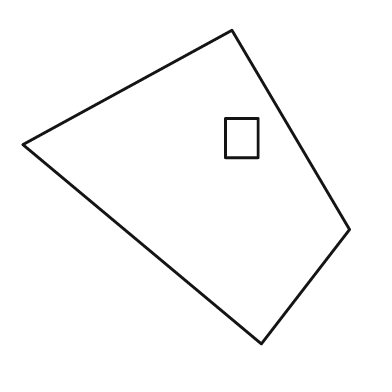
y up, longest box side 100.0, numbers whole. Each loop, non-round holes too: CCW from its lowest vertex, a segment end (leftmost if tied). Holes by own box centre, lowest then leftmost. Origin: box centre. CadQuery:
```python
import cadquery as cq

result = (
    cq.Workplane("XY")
    .moveTo(23.0, -48.0)
    .lineTo(50.0, -13.0)
    .lineTo(14.0, 48.0)
    .lineTo(-50.0, 13.0)
    .close()
    .moveTo(12.0, 9.0)
    .lineTo(22.0, 9.0)
    .lineTo(22.0, 21.0)
    .lineTo(12.0, 21.0)
    .close()
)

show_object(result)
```